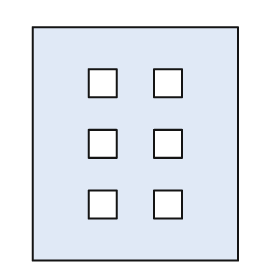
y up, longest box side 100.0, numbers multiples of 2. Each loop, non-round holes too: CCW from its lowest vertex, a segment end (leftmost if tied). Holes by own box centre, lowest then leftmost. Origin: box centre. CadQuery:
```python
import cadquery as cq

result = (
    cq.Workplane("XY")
    .moveTo(-44.0, -50.0)
    .lineTo(44.0, -50.0)
    .lineTo(44.0, 50.0)
    .lineTo(-44.0, 50.0)
    .close()
    .moveTo(-20.0, -32.0)
    .lineTo(-8.0, -32.0)
    .lineTo(-8.0, -20.0)
    .lineTo(-20.0, -20.0)
    .close()
    .moveTo(8.0, -32.0)
    .lineTo(20.0, -32.0)
    .lineTo(20.0, -20.0)
    .lineTo(8.0, -20.0)
    .close()
    .moveTo(-20.0, -6.0)
    .lineTo(-8.0, -6.0)
    .lineTo(-8.0, 6.0)
    .lineTo(-20.0, 6.0)
    .close()
    .moveTo(8.0, -6.0)
    .lineTo(20.0, -6.0)
    .lineTo(20.0, 6.0)
    .lineTo(8.0, 6.0)
    .close()
    .moveTo(-20.0, 20.0)
    .lineTo(-8.0, 20.0)
    .lineTo(-8.0, 32.0)
    .lineTo(-20.0, 32.0)
    .close()
    .moveTo(8.0, 20.0)
    .lineTo(20.0, 20.0)
    .lineTo(20.0, 32.0)
    .lineTo(8.0, 32.0)
    .close()
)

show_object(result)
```